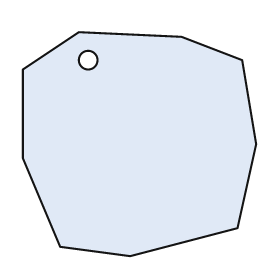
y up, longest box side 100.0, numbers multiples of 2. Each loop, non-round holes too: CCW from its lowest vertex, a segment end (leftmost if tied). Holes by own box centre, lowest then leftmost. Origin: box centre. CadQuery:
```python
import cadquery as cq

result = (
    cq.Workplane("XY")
    .moveTo(-4.0, -48.0)
    .lineTo(42.0, -36.0)
    .lineTo(50.0, 0.0)
    .lineTo(44.0, 36.0)
    .lineTo(18.0, 46.0)
    .lineTo(-26.0, 48.0)
    .lineTo(-50.0, 32.0)
    .lineTo(-50.0, -6.0)
    .lineTo(-34.0, -44.0)
    .close()
    .moveTo(-22.0, 36.0)
    .circle(4.0)
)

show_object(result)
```